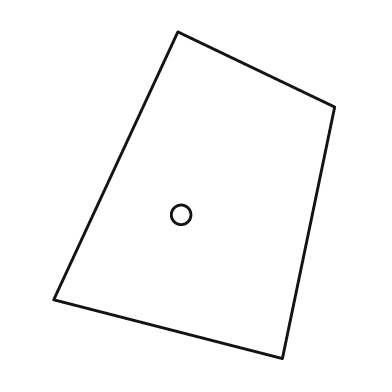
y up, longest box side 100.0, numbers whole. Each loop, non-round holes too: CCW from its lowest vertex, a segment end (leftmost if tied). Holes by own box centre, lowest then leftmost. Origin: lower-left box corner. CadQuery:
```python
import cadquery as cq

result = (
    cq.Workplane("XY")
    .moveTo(70.0, 0.0)
    .lineTo(86.0, 77.0)
    .lineTo(38.0, 100.0)
    .lineTo(0.0, 18.0)
    .close()
    .moveTo(39.0, 44.0)
    .circle(3.0)
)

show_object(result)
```